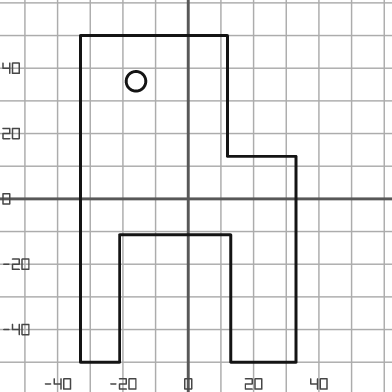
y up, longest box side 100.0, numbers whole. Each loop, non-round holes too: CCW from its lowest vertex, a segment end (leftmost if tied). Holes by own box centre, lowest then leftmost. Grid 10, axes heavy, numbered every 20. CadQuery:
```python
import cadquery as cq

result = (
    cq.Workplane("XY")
    .moveTo(-33.0, -50.0)
    .lineTo(-21.0, -50.0)
    .lineTo(-21.0, -11.0)
    .lineTo(13.0, -11.0)
    .lineTo(13.0, -50.0)
    .lineTo(33.0, -50.0)
    .lineTo(33.0, 13.0)
    .lineTo(12.0, 13.0)
    .lineTo(12.0, 50.0)
    .lineTo(-33.0, 50.0)
    .close()
    .moveTo(-16.0, 36.0)
    .circle(3.0)
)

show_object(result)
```